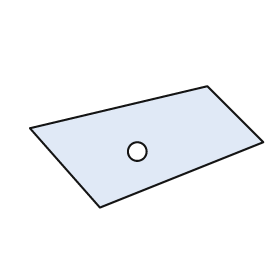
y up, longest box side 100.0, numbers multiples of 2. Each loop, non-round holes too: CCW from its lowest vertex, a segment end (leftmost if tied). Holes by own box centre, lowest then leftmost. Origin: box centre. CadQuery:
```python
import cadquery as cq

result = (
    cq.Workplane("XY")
    .moveTo(-20.0, -26.0)
    .lineTo(50.0, 2.0)
    .lineTo(26.0, 26.0)
    .lineTo(-50.0, 8.0)
    .close()
    .moveTo(-4.0, -2.0)
    .circle(4.0)
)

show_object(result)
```